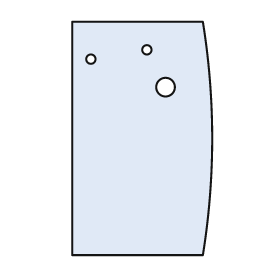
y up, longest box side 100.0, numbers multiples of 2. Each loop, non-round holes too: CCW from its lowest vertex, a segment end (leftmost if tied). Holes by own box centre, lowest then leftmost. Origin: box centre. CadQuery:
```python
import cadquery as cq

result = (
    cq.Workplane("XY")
    .moveTo(-30.0, -50.0)
    .lineTo(26.0, -50.0)
    .threePointArc((30.0, 0.0), (26.0, 50.0))
    .lineTo(-30.0, 50.0)
    .close()
    .moveTo(10.0, 22.0)
    .circle(4.0)
    .moveTo(-22.0, 34.0)
    .circle(2.0)
    .moveTo(2.0, 38.0)
    .circle(2.0)
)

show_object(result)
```